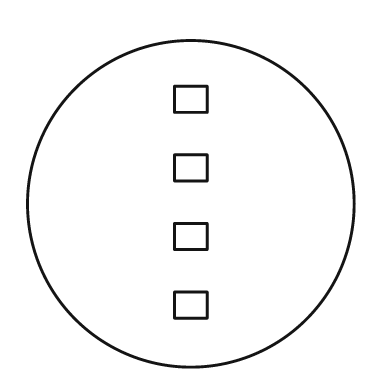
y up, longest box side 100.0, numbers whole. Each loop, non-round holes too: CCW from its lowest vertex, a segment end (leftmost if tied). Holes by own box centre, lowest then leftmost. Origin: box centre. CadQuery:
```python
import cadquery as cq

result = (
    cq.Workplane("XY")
    .moveTo(0.0, 0.0)
    .circle(50.0)
    .moveTo(-5.0, -35.0)
    .lineTo(5.0, -35.0)
    .lineTo(5.0, -27.0)
    .lineTo(-5.0, -27.0)
    .close()
    .moveTo(-5.0, -14.0)
    .lineTo(5.0, -14.0)
    .lineTo(5.0, -6.0)
    .lineTo(-5.0, -6.0)
    .close()
    .moveTo(-5.0, 7.0)
    .lineTo(5.0, 7.0)
    .lineTo(5.0, 15.0)
    .lineTo(-5.0, 15.0)
    .close()
    .moveTo(-5.0, 28.0)
    .lineTo(5.0, 28.0)
    .lineTo(5.0, 36.0)
    .lineTo(-5.0, 36.0)
    .close()
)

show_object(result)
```